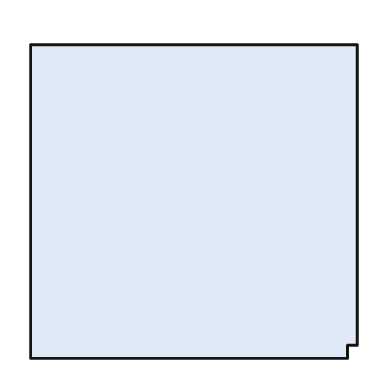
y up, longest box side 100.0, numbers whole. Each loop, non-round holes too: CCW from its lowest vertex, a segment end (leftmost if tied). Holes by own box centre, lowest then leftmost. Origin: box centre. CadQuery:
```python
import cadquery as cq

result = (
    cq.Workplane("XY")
    .moveTo(-50.0, -48.0)
    .lineTo(47.0, -48.0)
    .lineTo(47.0, -44.0)
    .lineTo(50.0, -44.0)
    .lineTo(50.0, 48.0)
    .lineTo(-50.0, 48.0)
    .close()
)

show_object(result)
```